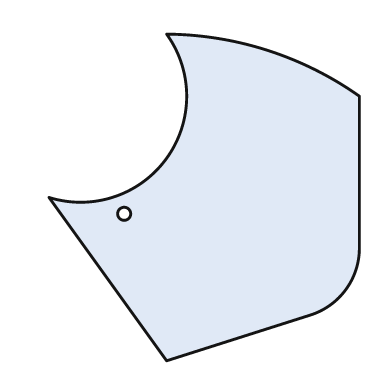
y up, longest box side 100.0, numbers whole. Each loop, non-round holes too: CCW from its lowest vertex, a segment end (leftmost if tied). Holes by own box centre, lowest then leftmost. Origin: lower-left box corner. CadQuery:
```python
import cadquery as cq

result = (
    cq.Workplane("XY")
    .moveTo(36.0, 0.0)
    .lineTo(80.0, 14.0)
    .threePointArc((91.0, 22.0), (95.0, 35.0))
    .lineTo(95.0, 81.0)
    .threePointArc((67.0, 95.0), (36.0, 100.0))
    .threePointArc((36.0, 62.0), (0.0, 50.0))
    .close()
    .moveTo(23.0, 45.0)
    .circle(2.0)
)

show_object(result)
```